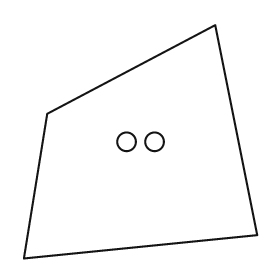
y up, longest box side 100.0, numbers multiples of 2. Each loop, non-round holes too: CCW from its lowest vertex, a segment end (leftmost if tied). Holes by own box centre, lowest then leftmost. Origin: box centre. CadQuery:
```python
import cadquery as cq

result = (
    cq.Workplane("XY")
    .moveTo(-50.0, -50.0)
    .lineTo(50.0, -40.0)
    .lineTo(32.0, 50.0)
    .lineTo(-40.0, 12.0)
    .close()
    .moveTo(-6.0, 0.0)
    .circle(4.0)
    .moveTo(6.0, 0.0)
    .circle(4.0)
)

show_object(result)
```